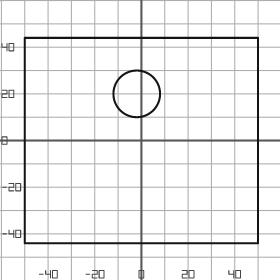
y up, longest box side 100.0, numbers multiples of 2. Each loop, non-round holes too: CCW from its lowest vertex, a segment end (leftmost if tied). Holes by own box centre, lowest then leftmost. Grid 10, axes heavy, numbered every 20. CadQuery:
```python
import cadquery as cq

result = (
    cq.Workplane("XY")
    .moveTo(-50.0, -44.0)
    .lineTo(50.0, -44.0)
    .lineTo(50.0, 44.0)
    .lineTo(-50.0, 44.0)
    .close()
    .moveTo(-2.0, 20.0)
    .circle(10.0)
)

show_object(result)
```